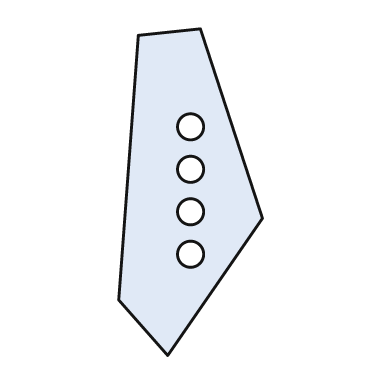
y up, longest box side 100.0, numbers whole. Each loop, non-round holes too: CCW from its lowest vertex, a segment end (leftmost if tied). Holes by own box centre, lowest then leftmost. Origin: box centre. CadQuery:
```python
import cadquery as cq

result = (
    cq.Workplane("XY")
    .moveTo(-7.0, -50.0)
    .lineTo(22.0, -8.0)
    .lineTo(3.0, 50.0)
    .lineTo(-16.0, 48.0)
    .lineTo(-22.0, -33.0)
    .close()
    .moveTo(0.0, -19.0)
    .circle(4.0)
    .moveTo(0.0, -6.0)
    .circle(4.0)
    .moveTo(0.0, 7.0)
    .circle(4.0)
    .moveTo(0.0, 20.0)
    .circle(4.0)
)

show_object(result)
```